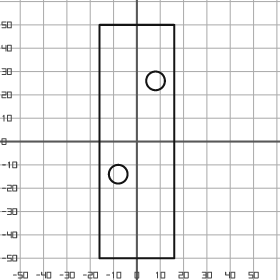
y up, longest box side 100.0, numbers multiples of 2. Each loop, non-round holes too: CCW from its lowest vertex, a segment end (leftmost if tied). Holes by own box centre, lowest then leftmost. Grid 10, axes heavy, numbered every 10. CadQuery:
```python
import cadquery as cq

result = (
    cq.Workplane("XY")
    .moveTo(-16.0, -50.0)
    .lineTo(16.0, -50.0)
    .lineTo(16.0, 50.0)
    .lineTo(-16.0, 50.0)
    .close()
    .moveTo(-8.0, -14.0)
    .circle(4.0)
    .moveTo(8.0, 26.0)
    .circle(4.0)
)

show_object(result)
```